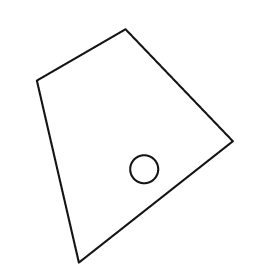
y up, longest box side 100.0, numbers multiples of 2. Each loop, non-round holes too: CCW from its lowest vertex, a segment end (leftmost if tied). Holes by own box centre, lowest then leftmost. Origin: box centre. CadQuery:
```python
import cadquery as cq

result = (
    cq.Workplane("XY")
    .moveTo(-24.0, -50.0)
    .lineTo(42.0, 2.0)
    .lineTo(-4.0, 50.0)
    .lineTo(-42.0, 28.0)
    .close()
    .moveTo(4.0, -10.0)
    .circle(6.0)
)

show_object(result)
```